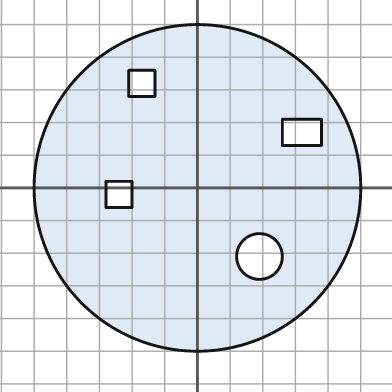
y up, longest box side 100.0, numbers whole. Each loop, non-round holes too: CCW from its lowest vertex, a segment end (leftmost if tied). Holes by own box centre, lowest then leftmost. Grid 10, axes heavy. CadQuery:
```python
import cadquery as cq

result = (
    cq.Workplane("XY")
    .moveTo(0.0, 0.0)
    .circle(50.0)
    .moveTo(19.0, -21.0)
    .circle(7.0)
    .moveTo(-28.0, -6.0)
    .lineTo(-20.0, -6.0)
    .lineTo(-20.0, 2.0)
    .lineTo(-28.0, 2.0)
    .close()
    .moveTo(26.0, 13.0)
    .lineTo(38.0, 13.0)
    .lineTo(38.0, 21.0)
    .lineTo(26.0, 21.0)
    .close()
    .moveTo(-21.0, 28.0)
    .lineTo(-13.0, 28.0)
    .lineTo(-13.0, 36.0)
    .lineTo(-21.0, 36.0)
    .close()
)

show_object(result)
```